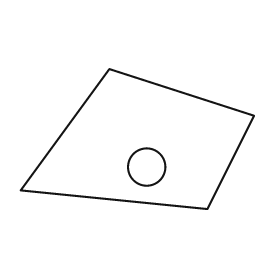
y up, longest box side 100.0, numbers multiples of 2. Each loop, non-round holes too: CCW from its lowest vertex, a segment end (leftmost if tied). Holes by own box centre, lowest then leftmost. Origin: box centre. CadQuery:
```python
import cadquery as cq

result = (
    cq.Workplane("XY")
    .moveTo(30.0, -30.0)
    .lineTo(50.0, 10.0)
    .lineTo(-12.0, 30.0)
    .lineTo(-50.0, -22.0)
    .close()
    .moveTo(4.0, -12.0)
    .circle(8.0)
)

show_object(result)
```